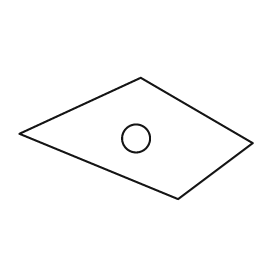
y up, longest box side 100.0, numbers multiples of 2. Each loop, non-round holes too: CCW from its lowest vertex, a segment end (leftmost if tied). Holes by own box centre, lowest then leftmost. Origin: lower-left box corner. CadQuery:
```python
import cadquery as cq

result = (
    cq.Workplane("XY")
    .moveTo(68.0, 0.0)
    .lineTo(100.0, 24.0)
    .lineTo(52.0, 52.0)
    .lineTo(0.0, 28.0)
    .close()
    .moveTo(50.0, 26.0)
    .circle(6.0)
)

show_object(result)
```